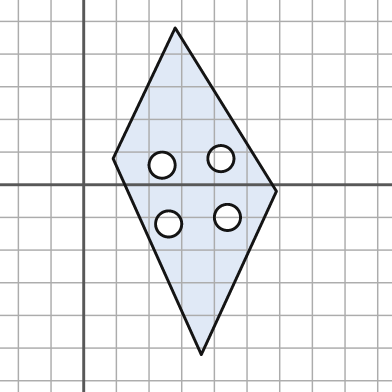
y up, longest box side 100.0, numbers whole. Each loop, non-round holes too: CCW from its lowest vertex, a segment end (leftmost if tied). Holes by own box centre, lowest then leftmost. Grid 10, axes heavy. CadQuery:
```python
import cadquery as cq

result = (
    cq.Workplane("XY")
    .moveTo(36.0, -52.0)
    .lineTo(59.0, -2.0)
    .lineTo(28.0, 48.0)
    .lineTo(9.0, 8.0)
    .close()
    .moveTo(26.0, -12.0)
    .circle(4.0)
    .moveTo(44.0, -10.0)
    .circle(4.0)
    .moveTo(24.0, 6.0)
    .circle(4.0)
    .moveTo(42.0, 8.0)
    .circle(4.0)
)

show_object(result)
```